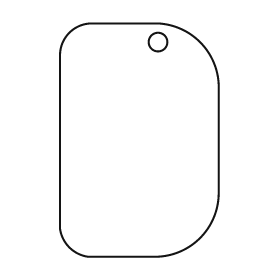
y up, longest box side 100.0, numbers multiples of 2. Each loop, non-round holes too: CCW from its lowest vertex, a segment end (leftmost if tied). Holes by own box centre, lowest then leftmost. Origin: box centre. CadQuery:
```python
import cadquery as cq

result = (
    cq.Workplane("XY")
    .moveTo(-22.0, -50.0)
    .lineTo(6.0, -50.0)
    .threePointArc((26.0, -42.0), (34.0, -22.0))
    .lineTo(34.0, 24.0)
    .threePointArc((26.0, 42.0), (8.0, 50.0))
    .lineTo(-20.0, 50.0)
    .threePointArc((-30.0, 46.0), (-34.0, 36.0))
    .lineTo(-34.0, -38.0)
    .threePointArc((-30.0, -46.0), (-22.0, -50.0))
    .close()
    .moveTo(8.0, 42.0)
    .circle(4.0)
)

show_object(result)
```